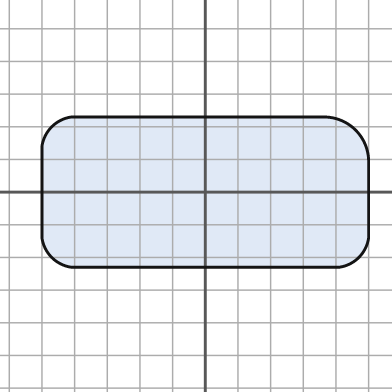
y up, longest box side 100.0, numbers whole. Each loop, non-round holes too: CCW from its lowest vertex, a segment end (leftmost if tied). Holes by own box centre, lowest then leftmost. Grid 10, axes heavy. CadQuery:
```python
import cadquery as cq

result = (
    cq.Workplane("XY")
    .moveTo(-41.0, -23.0)
    .lineTo(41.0, -23.0)
    .threePointArc((47.0, -20.0), (50.0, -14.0))
    .lineTo(50.0, 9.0)
    .threePointArc((46.0, 19.0), (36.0, 23.0))
    .lineTo(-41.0, 23.0)
    .threePointArc((-47.0, 20.0), (-50.0, 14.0))
    .lineTo(-50.0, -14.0)
    .threePointArc((-47.0, -20.0), (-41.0, -23.0))
    .close()
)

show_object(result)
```